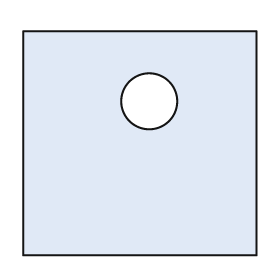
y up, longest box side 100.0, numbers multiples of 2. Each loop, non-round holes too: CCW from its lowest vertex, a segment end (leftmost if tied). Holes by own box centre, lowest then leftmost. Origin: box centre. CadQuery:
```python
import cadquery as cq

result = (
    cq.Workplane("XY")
    .moveTo(-50.0, -48.0)
    .lineTo(50.0, -48.0)
    .lineTo(50.0, 48.0)
    .lineTo(-50.0, 48.0)
    .close()
    .moveTo(4.0, 18.0)
    .circle(12.0)
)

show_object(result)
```